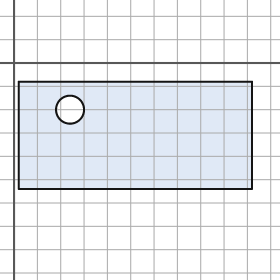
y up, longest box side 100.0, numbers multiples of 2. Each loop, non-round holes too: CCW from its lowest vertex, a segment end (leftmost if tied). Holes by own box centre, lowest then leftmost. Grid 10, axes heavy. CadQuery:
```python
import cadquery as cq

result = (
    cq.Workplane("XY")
    .moveTo(2.0, -54.0)
    .lineTo(102.0, -54.0)
    .lineTo(102.0, -8.0)
    .lineTo(2.0, -8.0)
    .close()
    .moveTo(24.0, -20.0)
    .circle(6.0)
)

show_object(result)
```